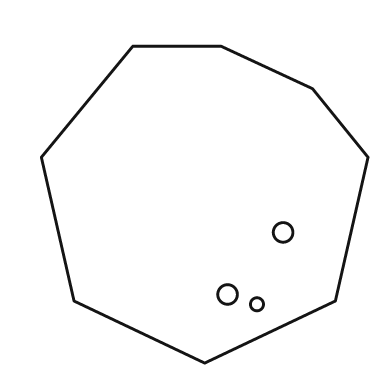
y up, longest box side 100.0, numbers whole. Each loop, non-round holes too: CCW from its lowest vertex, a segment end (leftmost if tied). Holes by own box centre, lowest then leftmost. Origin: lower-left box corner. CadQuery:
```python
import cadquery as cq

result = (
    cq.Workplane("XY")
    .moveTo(50.0, 0.0)
    .lineTo(90.0, 19.0)
    .lineTo(100.0, 63.0)
    .lineTo(83.0, 84.0)
    .lineTo(55.0, 97.0)
    .lineTo(28.0, 97.0)
    .lineTo(0.0, 63.0)
    .lineTo(10.0, 19.0)
    .close()
    .moveTo(66.0, 18.0)
    .circle(2.0)
    .moveTo(57.0, 21.0)
    .circle(3.0)
    .moveTo(74.0, 40.0)
    .circle(3.0)
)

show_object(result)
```